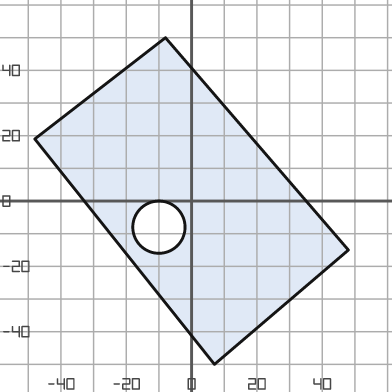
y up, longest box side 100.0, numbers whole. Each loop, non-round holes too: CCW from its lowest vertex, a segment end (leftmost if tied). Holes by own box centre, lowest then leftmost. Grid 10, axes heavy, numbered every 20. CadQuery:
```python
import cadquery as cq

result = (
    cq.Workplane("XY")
    .moveTo(7.0, -50.0)
    .lineTo(48.0, -15.0)
    .lineTo(-8.0, 50.0)
    .lineTo(-48.0, 19.0)
    .close()
    .moveTo(-10.0, -8.0)
    .circle(8.0)
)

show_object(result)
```